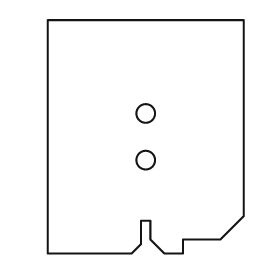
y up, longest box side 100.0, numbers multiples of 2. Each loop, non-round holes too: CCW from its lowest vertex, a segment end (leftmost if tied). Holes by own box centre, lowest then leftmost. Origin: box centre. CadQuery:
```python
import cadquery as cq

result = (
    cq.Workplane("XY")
    .moveTo(-42.0, -50.0)
    .lineTo(-6.0, -50.0)
    .lineTo(-2.0, -46.0)
    .lineTo(-2.0, -36.0)
    .lineTo(2.0, -36.0)
    .lineTo(2.0, -44.0)
    .lineTo(8.0, -50.0)
    .lineTo(16.0, -50.0)
    .lineTo(16.0, -44.0)
    .lineTo(32.0, -44.0)
    .lineTo(42.0, -34.0)
    .lineTo(42.0, 50.0)
    .lineTo(-42.0, 50.0)
    .close()
    .moveTo(0.0, -10.0)
    .circle(4.0)
    .moveTo(0.0, 10.0)
    .circle(4.0)
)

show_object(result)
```